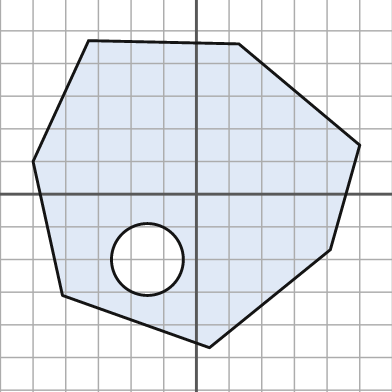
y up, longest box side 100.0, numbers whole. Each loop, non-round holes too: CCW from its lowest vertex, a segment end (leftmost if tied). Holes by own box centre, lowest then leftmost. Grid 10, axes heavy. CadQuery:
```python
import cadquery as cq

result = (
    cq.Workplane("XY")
    .moveTo(4.0, -47.0)
    .lineTo(41.0, -17.0)
    .lineTo(50.0, 15.0)
    .lineTo(13.0, 46.0)
    .lineTo(-33.0, 47.0)
    .lineTo(-50.0, 10.0)
    .lineTo(-41.0, -31.0)
    .close()
    .moveTo(-15.0, -20.0)
    .circle(11.0)
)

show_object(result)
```